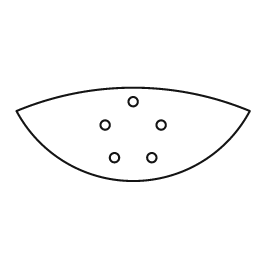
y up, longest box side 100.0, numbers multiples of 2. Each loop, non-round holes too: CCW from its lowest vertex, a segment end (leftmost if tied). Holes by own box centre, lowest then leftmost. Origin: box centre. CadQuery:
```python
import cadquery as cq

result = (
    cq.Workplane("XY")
    .moveTo(-50.0, 10.0)
    .threePointArc((0.0, -20.0), (50.0, 10.0))
    .threePointArc((0.0, 20.0), (-50.0, 10.0))
    .close()
    .moveTo(-8.0, -10.0)
    .circle(2.0)
    .moveTo(8.0, -10.0)
    .circle(2.0)
    .moveTo(-12.0, 4.0)
    .circle(2.0)
    .moveTo(12.0, 4.0)
    .circle(2.0)
    .moveTo(0.0, 14.0)
    .circle(2.0)
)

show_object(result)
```